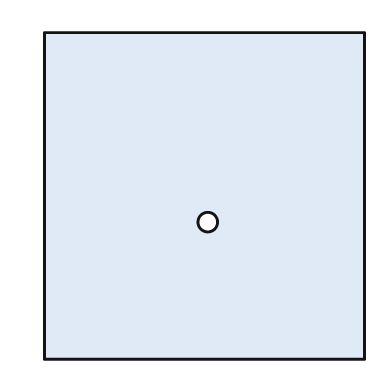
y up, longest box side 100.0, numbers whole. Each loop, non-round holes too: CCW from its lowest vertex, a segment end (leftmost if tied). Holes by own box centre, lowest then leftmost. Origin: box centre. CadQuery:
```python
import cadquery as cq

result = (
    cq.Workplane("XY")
    .moveTo(-49.0, -50.0)
    .lineTo(49.0, -50.0)
    .lineTo(49.0, 50.0)
    .lineTo(-49.0, 50.0)
    .close()
    .moveTo(1.0, -8.0)
    .circle(3.0)
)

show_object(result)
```